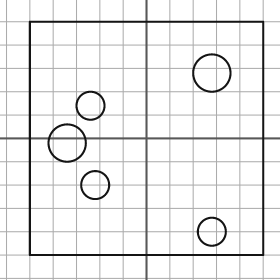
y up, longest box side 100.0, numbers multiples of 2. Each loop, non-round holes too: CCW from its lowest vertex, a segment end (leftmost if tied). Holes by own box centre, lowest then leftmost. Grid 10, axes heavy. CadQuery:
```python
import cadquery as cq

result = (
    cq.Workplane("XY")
    .moveTo(-50.0, -50.0)
    .lineTo(50.0, -50.0)
    .lineTo(50.0, 50.0)
    .lineTo(-50.0, 50.0)
    .close()
    .moveTo(28.0, -40.0)
    .circle(6.0)
    .moveTo(-22.0, -20.0)
    .circle(6.0)
    .moveTo(-34.0, -2.0)
    .circle(8.0)
    .moveTo(-24.0, 14.0)
    .circle(6.0)
    .moveTo(28.0, 28.0)
    .circle(8.0)
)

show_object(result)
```